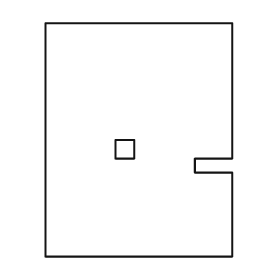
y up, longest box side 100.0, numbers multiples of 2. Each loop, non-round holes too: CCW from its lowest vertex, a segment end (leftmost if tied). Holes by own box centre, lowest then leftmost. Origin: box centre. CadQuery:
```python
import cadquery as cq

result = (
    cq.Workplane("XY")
    .moveTo(-40.0, -50.0)
    .lineTo(40.0, -50.0)
    .lineTo(40.0, -14.0)
    .lineTo(24.0, -14.0)
    .lineTo(24.0, -8.0)
    .lineTo(40.0, -8.0)
    .lineTo(40.0, 50.0)
    .lineTo(-40.0, 50.0)
    .close()
    .moveTo(-10.0, -8.0)
    .lineTo(-2.0, -8.0)
    .lineTo(-2.0, 0.0)
    .lineTo(-10.0, 0.0)
    .close()
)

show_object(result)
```